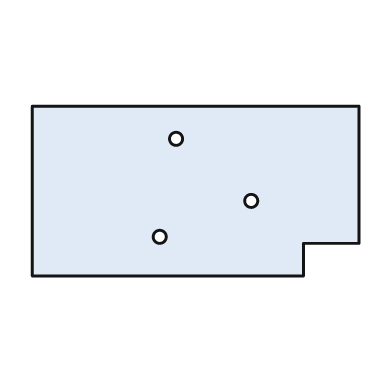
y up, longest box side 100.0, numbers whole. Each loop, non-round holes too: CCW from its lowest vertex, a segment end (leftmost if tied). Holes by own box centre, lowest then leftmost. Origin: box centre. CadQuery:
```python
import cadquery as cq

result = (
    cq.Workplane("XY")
    .moveTo(-50.0, -26.0)
    .lineTo(33.0, -26.0)
    .lineTo(33.0, -16.0)
    .lineTo(50.0, -16.0)
    .lineTo(50.0, 26.0)
    .lineTo(-50.0, 26.0)
    .close()
    .moveTo(-11.0, -14.0)
    .circle(2.0)
    .moveTo(17.0, -3.0)
    .circle(2.0)
    .moveTo(-6.0, 16.0)
    .circle(2.0)
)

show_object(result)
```